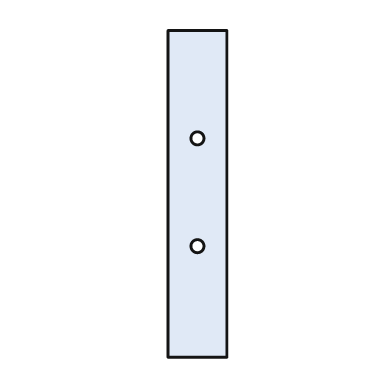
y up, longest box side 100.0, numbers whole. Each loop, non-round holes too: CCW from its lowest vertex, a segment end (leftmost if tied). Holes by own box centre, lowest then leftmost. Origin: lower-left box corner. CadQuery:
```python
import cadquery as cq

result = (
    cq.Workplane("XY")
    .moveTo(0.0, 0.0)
    .lineTo(18.0, 0.0)
    .lineTo(18.0, 100.0)
    .lineTo(0.0, 100.0)
    .close()
    .moveTo(9.0, 34.0)
    .circle(2.0)
    .moveTo(9.0, 67.0)
    .circle(2.0)
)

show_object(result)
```